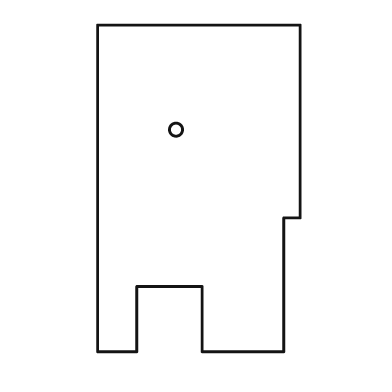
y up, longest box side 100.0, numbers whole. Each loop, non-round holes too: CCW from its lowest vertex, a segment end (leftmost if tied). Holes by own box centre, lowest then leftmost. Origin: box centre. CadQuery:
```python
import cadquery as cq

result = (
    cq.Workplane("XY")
    .moveTo(-31.0, -50.0)
    .lineTo(-19.0, -50.0)
    .lineTo(-19.0, -30.0)
    .lineTo(1.0, -30.0)
    .lineTo(1.0, -50.0)
    .lineTo(26.0, -50.0)
    .lineTo(26.0, -9.0)
    .lineTo(31.0, -9.0)
    .lineTo(31.0, 50.0)
    .lineTo(-31.0, 50.0)
    .close()
    .moveTo(-7.0, 18.0)
    .circle(2.0)
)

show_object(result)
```